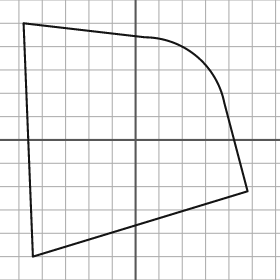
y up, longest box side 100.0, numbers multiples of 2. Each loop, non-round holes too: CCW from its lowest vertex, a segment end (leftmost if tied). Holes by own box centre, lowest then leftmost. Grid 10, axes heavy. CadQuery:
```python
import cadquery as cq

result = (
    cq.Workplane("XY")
    .moveTo(-44.0, -50.0)
    .lineTo(48.0, -22.0)
    .lineTo(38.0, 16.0)
    .threePointArc((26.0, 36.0), (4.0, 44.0))
    .lineTo(-48.0, 50.0)
    .close()
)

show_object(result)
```